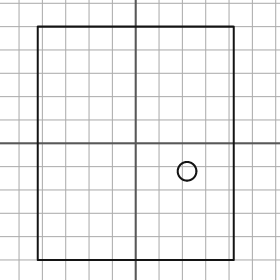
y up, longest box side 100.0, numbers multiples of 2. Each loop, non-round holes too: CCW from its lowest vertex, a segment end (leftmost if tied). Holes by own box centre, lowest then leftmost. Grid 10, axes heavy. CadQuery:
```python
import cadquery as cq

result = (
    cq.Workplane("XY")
    .moveTo(-42.0, -50.0)
    .lineTo(42.0, -50.0)
    .lineTo(42.0, 50.0)
    .lineTo(-42.0, 50.0)
    .close()
    .moveTo(22.0, -12.0)
    .circle(4.0)
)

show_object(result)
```